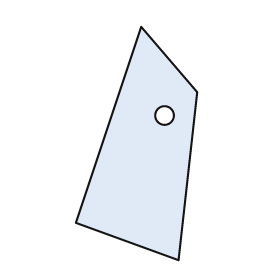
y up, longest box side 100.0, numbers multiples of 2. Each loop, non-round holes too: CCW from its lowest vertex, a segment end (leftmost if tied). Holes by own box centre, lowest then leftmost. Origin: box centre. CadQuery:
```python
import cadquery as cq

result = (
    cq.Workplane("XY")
    .moveTo(18.0, -50.0)
    .lineTo(26.0, 22.0)
    .lineTo(2.0, 50.0)
    .lineTo(-26.0, -34.0)
    .close()
    .moveTo(12.0, 12.0)
    .circle(4.0)
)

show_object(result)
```